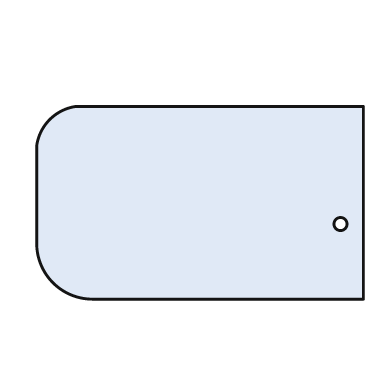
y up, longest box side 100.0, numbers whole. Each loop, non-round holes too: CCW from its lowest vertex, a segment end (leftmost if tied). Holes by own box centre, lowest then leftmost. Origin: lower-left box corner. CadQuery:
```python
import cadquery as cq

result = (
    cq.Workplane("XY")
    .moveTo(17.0, 0.0)
    .lineTo(100.0, 0.0)
    .lineTo(100.0, 59.0)
    .lineTo(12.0, 59.0)
    .threePointArc((4.0, 55.0), (0.0, 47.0))
    .lineTo(0.0, 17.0)
    .threePointArc((5.0, 5.0), (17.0, 0.0))
    .close()
    .moveTo(93.0, 23.0)
    .circle(2.0)
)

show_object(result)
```